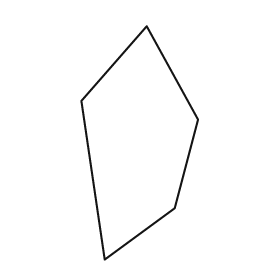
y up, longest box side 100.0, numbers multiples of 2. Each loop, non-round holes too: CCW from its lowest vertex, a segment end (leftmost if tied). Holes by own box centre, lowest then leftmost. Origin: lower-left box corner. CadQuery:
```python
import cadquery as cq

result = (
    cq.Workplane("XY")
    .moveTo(10.0, 0.0)
    .lineTo(40.0, 22.0)
    .lineTo(50.0, 60.0)
    .lineTo(28.0, 100.0)
    .lineTo(0.0, 68.0)
    .close()
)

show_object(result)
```